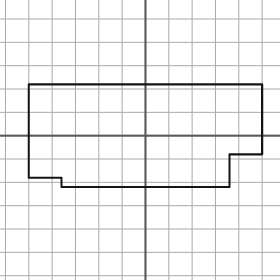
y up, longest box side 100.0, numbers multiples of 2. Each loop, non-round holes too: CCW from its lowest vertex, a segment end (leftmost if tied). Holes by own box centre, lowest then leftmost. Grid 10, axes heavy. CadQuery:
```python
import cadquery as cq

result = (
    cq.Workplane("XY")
    .moveTo(-36.0, -22.0)
    .lineTo(36.0, -22.0)
    .lineTo(36.0, -8.0)
    .lineTo(50.0, -8.0)
    .lineTo(50.0, 22.0)
    .lineTo(-50.0, 22.0)
    .lineTo(-50.0, -18.0)
    .lineTo(-36.0, -18.0)
    .close()
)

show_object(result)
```